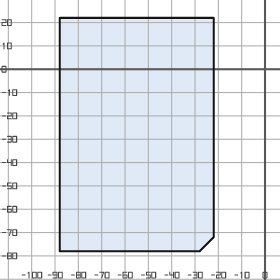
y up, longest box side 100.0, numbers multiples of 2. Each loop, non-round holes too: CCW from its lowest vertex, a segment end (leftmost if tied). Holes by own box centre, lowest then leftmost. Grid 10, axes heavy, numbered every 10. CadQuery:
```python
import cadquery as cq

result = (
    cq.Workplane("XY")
    .moveTo(-88.0, -78.0)
    .lineTo(-28.0, -78.0)
    .lineTo(-22.0, -72.0)
    .lineTo(-22.0, 22.0)
    .lineTo(-88.0, 22.0)
    .close()
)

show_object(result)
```